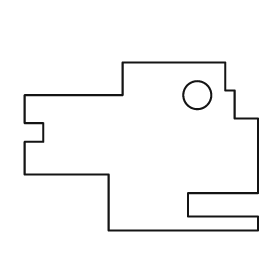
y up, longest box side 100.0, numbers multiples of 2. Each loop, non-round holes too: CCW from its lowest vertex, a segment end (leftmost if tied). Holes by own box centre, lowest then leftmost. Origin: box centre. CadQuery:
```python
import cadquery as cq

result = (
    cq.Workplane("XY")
    .moveTo(-14.0, -36.0)
    .lineTo(50.0, -36.0)
    .lineTo(50.0, -30.0)
    .lineTo(20.0, -30.0)
    .lineTo(20.0, -20.0)
    .lineTo(50.0, -20.0)
    .lineTo(50.0, 12.0)
    .lineTo(40.0, 12.0)
    .lineTo(40.0, 24.0)
    .lineTo(36.0, 24.0)
    .lineTo(36.0, 36.0)
    .lineTo(-8.0, 36.0)
    .lineTo(-8.0, 22.0)
    .lineTo(-50.0, 22.0)
    .lineTo(-50.0, 10.0)
    .lineTo(-42.0, 10.0)
    .lineTo(-42.0, 2.0)
    .lineTo(-50.0, 2.0)
    .lineTo(-50.0, -12.0)
    .lineTo(-14.0, -12.0)
    .close()
    .moveTo(24.0, 22.0)
    .circle(6.0)
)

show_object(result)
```